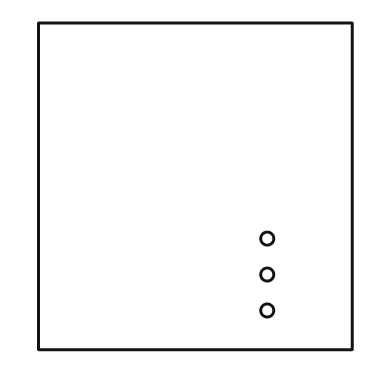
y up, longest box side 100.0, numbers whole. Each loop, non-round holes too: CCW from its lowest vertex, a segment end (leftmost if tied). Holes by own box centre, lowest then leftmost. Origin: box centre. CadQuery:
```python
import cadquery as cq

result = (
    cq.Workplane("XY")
    .moveTo(-48.0, -50.0)
    .lineTo(48.0, -50.0)
    .lineTo(48.0, 50.0)
    .lineTo(-48.0, 50.0)
    .close()
    .moveTo(22.0, -38.0)
    .circle(2.0)
    .moveTo(22.0, -27.0)
    .circle(2.0)
    .moveTo(22.0, -16.0)
    .circle(2.0)
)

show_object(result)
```